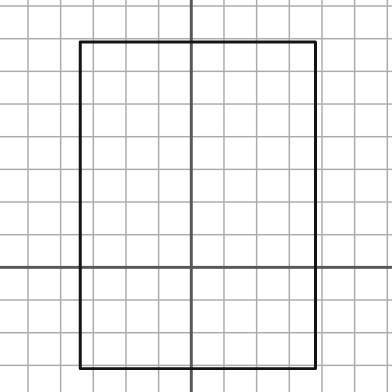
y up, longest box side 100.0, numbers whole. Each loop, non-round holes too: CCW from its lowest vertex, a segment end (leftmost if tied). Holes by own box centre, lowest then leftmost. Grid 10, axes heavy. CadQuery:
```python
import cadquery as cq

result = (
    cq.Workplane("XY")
    .moveTo(-34.0, -31.0)
    .lineTo(38.0, -31.0)
    .lineTo(38.0, 69.0)
    .lineTo(-34.0, 69.0)
    .close()
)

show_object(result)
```